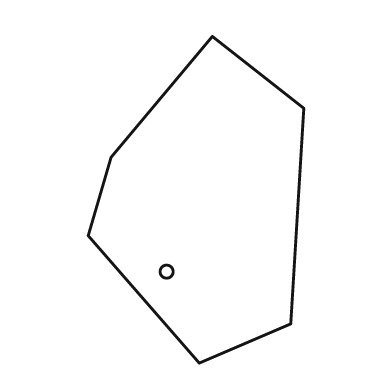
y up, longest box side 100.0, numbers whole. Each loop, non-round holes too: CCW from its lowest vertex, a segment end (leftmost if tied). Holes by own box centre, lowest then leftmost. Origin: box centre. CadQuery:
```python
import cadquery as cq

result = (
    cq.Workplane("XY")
    .moveTo(1.0, -50.0)
    .lineTo(29.0, -38.0)
    .lineTo(33.0, 28.0)
    .lineTo(5.0, 50.0)
    .lineTo(-26.0, 13.0)
    .lineTo(-33.0, -11.0)
    .close()
    .moveTo(-9.0, -22.0)
    .circle(2.0)
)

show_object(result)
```